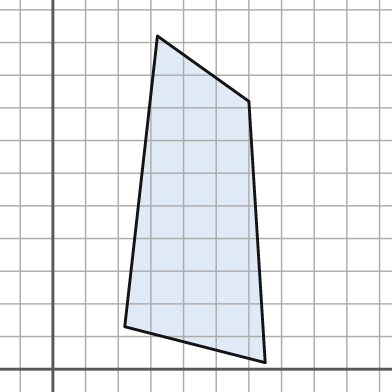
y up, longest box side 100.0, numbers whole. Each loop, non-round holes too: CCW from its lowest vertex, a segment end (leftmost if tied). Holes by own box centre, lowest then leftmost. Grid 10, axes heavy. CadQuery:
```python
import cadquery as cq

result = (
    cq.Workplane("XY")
    .moveTo(65.0, 2.0)
    .lineTo(60.0, 82.0)
    .lineTo(32.0, 102.0)
    .lineTo(22.0, 13.0)
    .close()
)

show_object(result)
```